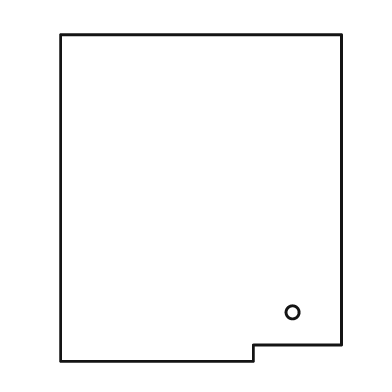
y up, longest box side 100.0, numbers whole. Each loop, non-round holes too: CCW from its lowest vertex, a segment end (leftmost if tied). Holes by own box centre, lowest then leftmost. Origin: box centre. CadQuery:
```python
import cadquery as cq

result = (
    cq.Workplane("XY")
    .moveTo(-43.0, -50.0)
    .lineTo(16.0, -50.0)
    .lineTo(16.0, -45.0)
    .lineTo(43.0, -45.0)
    .lineTo(43.0, 50.0)
    .lineTo(-43.0, 50.0)
    .close()
    .moveTo(28.0, -35.0)
    .circle(2.0)
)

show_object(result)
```